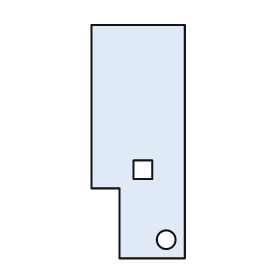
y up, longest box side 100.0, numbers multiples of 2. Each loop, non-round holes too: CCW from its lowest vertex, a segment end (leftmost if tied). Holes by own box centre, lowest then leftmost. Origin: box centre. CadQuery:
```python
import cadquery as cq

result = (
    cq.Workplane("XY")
    .moveTo(-8.0, -50.0)
    .lineTo(20.0, -50.0)
    .lineTo(20.0, 50.0)
    .lineTo(-20.0, 50.0)
    .lineTo(-20.0, -20.0)
    .lineTo(-8.0, -20.0)
    .close()
    .moveTo(12.0, -42.0)
    .circle(4.0)
    .moveTo(-2.0, -16.0)
    .lineTo(6.0, -16.0)
    .lineTo(6.0, -8.0)
    .lineTo(-2.0, -8.0)
    .close()
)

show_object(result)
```